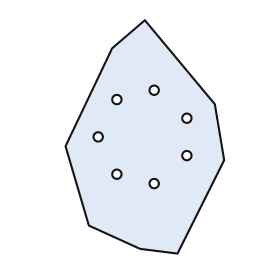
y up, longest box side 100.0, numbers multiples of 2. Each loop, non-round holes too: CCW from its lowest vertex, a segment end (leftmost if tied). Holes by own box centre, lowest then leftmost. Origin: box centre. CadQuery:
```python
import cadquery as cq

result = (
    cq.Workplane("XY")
    .moveTo(14.0, -50.0)
    .lineTo(34.0, -10.0)
    .lineTo(30.0, 14.0)
    .lineTo(0.0, 50.0)
    .lineTo(-14.0, 38.0)
    .lineTo(-34.0, -4.0)
    .lineTo(-24.0, -38.0)
    .lineTo(-2.0, -48.0)
    .close()
    .moveTo(4.0, -20.0)
    .circle(2.0)
    .moveTo(-12.0, -16.0)
    .circle(2.0)
    .moveTo(18.0, -8.0)
    .circle(2.0)
    .moveTo(-20.0, 0.0)
    .circle(2.0)
    .moveTo(18.0, 8.0)
    .circle(2.0)
    .moveTo(-12.0, 16.0)
    .circle(2.0)
    .moveTo(4.0, 20.0)
    .circle(2.0)
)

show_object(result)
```